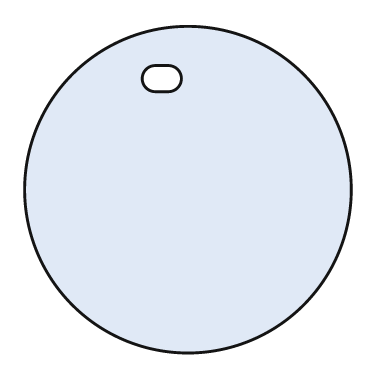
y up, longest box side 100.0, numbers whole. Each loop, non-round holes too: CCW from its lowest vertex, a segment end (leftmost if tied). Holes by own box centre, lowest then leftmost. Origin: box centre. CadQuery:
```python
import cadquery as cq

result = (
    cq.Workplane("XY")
    .moveTo(0.0, 0.0)
    .circle(50.0)
    .moveTo(-10.0, 30.0)
    .lineTo(-6.0, 30.0)
    .threePointArc((-2.0, 34.0), (-6.0, 38.0))
    .lineTo(-10.0, 38.0)
    .threePointArc((-14.0, 34.0), (-10.0, 30.0))
    .close()
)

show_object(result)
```